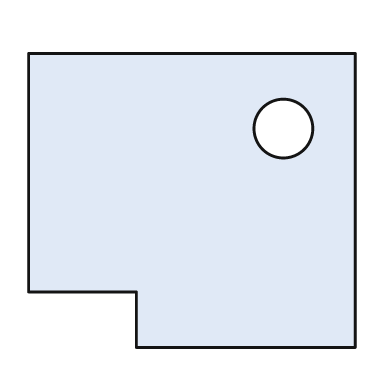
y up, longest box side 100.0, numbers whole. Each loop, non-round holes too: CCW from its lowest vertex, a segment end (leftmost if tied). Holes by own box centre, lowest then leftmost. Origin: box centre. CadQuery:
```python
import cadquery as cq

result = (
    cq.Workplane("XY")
    .moveTo(-17.0, -45.0)
    .lineTo(50.0, -45.0)
    .lineTo(50.0, 45.0)
    .lineTo(-50.0, 45.0)
    .lineTo(-50.0, -28.0)
    .lineTo(-17.0, -28.0)
    .close()
    .moveTo(28.0, 22.0)
    .circle(9.0)
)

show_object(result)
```